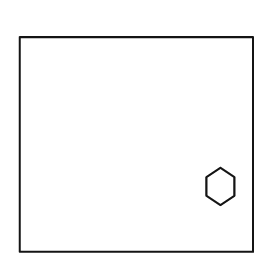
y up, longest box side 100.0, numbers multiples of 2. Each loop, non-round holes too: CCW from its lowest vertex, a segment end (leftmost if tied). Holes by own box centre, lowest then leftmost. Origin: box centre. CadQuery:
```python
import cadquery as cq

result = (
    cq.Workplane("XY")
    .moveTo(-50.0, -46.0)
    .lineTo(50.0, -46.0)
    .lineTo(50.0, 46.0)
    .lineTo(-50.0, 46.0)
    .close()
    .moveTo(36.0, -26.0)
    .lineTo(42.0, -22.0)
    .lineTo(42.0, -14.0)
    .lineTo(36.0, -10.0)
    .lineTo(30.0, -14.0)
    .lineTo(30.0, -22.0)
    .close()
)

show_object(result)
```